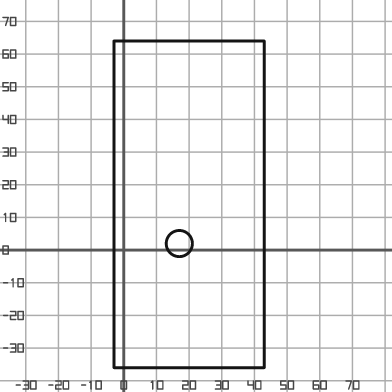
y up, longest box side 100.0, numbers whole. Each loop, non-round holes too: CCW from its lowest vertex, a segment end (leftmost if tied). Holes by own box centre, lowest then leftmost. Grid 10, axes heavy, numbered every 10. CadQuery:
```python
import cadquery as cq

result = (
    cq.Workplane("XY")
    .moveTo(-3.0, -36.0)
    .lineTo(43.0, -36.0)
    .lineTo(43.0, 64.0)
    .lineTo(-3.0, 64.0)
    .close()
    .moveTo(17.0, 2.0)
    .circle(4.0)
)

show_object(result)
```